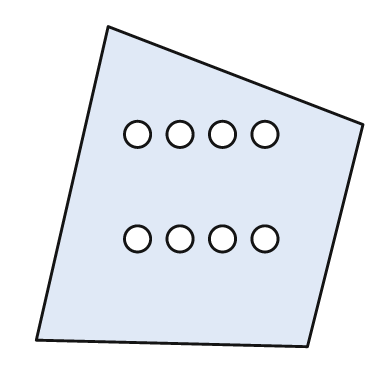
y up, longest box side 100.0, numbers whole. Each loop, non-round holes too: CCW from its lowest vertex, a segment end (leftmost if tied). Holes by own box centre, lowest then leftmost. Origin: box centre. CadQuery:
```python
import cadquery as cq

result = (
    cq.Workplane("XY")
    .moveTo(33.0, -49.0)
    .lineTo(50.0, 19.0)
    .lineTo(-28.0, 49.0)
    .lineTo(-50.0, -47.0)
    .close()
    .moveTo(-19.0, -16.0)
    .circle(4.0)
    .moveTo(-6.0, -16.0)
    .circle(4.0)
    .moveTo(7.0, -16.0)
    .circle(4.0)
    .moveTo(20.0, -16.0)
    .circle(4.0)
    .moveTo(-19.0, 16.0)
    .circle(4.0)
    .moveTo(-6.0, 16.0)
    .circle(4.0)
    .moveTo(7.0, 16.0)
    .circle(4.0)
    .moveTo(20.0, 16.0)
    .circle(4.0)
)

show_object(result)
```